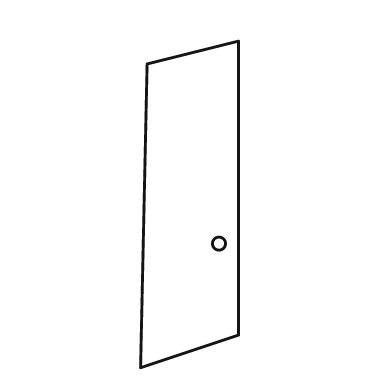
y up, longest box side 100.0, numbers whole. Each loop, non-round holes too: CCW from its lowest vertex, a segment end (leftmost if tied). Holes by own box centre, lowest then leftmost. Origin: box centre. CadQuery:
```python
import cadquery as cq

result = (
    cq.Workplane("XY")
    .moveTo(-15.0, -50.0)
    .lineTo(15.0, -40.0)
    .lineTo(15.0, 50.0)
    .lineTo(-13.0, 43.0)
    .close()
    .moveTo(9.0, -12.0)
    .circle(2.0)
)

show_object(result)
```